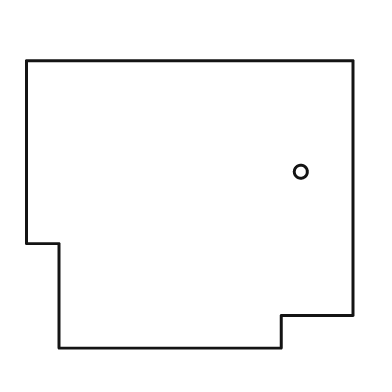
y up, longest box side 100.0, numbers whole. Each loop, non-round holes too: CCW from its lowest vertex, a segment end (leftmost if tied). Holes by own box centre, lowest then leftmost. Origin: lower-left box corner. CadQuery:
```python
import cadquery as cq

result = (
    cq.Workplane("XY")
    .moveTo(10.0, 0.0)
    .lineTo(78.0, 0.0)
    .lineTo(78.0, 10.0)
    .lineTo(100.0, 10.0)
    .lineTo(100.0, 88.0)
    .lineTo(0.0, 88.0)
    .lineTo(0.0, 32.0)
    .lineTo(10.0, 32.0)
    .close()
    .moveTo(84.0, 54.0)
    .circle(2.0)
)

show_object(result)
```